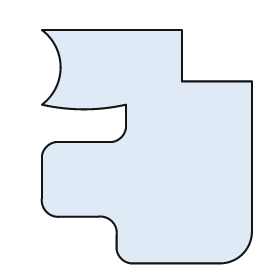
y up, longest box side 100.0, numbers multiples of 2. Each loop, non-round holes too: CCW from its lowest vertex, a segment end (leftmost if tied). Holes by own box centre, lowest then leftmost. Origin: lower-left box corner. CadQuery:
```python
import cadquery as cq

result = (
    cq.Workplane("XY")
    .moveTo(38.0, 0.0)
    .lineTo(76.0, 0.0)
    .threePointArc((86.0, 4.0), (90.0, 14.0))
    .lineTo(90.0, 78.0)
    .lineTo(60.0, 78.0)
    .lineTo(60.0, 100.0)
    .lineTo(0.0, 100.0)
    .threePointArc((8.0, 84.0), (0.0, 68.0))
    .threePointArc((18.0, 66.0), (36.0, 68.0))
    .lineTo(36.0, 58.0)
    .threePointArc((34.0, 54.0), (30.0, 52.0))
    .lineTo(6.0, 52.0)
    .threePointArc((2.0, 50.0), (0.0, 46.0))
    .lineTo(0.0, 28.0)
    .threePointArc((2.0, 22.0), (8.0, 20.0))
    .lineTo(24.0, 20.0)
    .threePointArc((30.0, 18.0), (32.0, 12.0))
    .lineTo(32.0, 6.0)
    .threePointArc((34.0, 2.0), (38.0, 0.0))
    .close()
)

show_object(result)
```